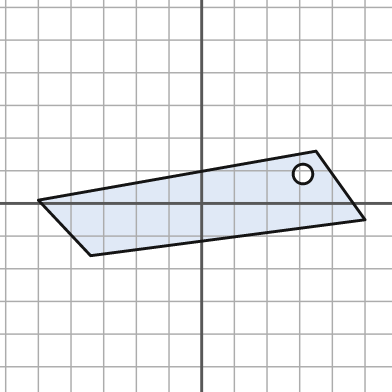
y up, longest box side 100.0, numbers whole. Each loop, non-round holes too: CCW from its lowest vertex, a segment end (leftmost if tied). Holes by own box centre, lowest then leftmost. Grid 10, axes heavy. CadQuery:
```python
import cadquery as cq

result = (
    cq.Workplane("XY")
    .moveTo(-34.0, -16.0)
    .lineTo(50.0, -5.0)
    .lineTo(35.0, 16.0)
    .lineTo(-50.0, 1.0)
    .close()
    .moveTo(31.0, 9.0)
    .circle(3.0)
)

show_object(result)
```